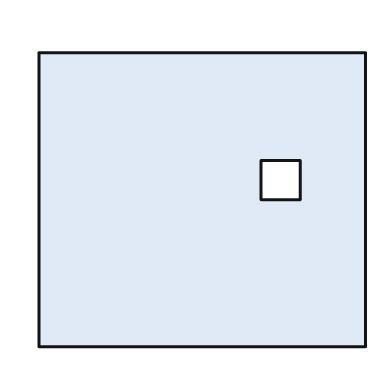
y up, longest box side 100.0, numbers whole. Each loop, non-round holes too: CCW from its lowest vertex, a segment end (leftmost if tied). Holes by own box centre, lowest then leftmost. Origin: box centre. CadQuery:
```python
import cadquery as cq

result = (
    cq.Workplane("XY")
    .moveTo(-50.0, -45.0)
    .lineTo(50.0, -45.0)
    .lineTo(50.0, 45.0)
    .lineTo(-50.0, 45.0)
    .close()
    .moveTo(18.0, 0.0)
    .lineTo(30.0, 0.0)
    .lineTo(30.0, 12.0)
    .lineTo(18.0, 12.0)
    .close()
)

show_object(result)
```